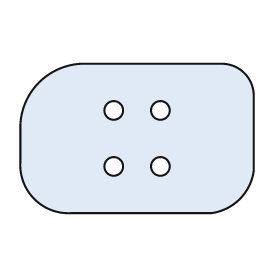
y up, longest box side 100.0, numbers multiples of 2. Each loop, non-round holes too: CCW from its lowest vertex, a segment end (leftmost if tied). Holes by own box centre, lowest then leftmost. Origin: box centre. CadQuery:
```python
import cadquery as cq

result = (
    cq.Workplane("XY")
    .moveTo(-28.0, -32.0)
    .lineTo(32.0, -32.0)
    .threePointArc((44.0, -26.0), (50.0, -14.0))
    .lineTo(50.0, 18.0)
    .threePointArc((46.0, 28.0), (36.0, 32.0))
    .lineTo(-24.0, 32.0)
    .threePointArc((-42.0, 24.0), (-50.0, 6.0))
    .lineTo(-50.0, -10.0)
    .threePointArc((-44.0, -26.0), (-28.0, -32.0))
    .close()
    .moveTo(-10.0, -12.0)
    .circle(4.0)
    .moveTo(10.0, -12.0)
    .circle(4.0)
    .moveTo(-10.0, 12.0)
    .circle(4.0)
    .moveTo(10.0, 12.0)
    .circle(4.0)
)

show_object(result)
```